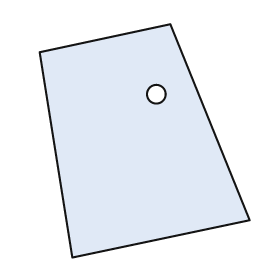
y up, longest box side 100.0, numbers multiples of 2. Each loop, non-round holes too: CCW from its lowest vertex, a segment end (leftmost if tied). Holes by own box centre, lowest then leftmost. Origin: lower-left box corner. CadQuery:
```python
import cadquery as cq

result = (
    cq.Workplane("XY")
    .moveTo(14.0, 0.0)
    .lineTo(90.0, 16.0)
    .lineTo(56.0, 100.0)
    .lineTo(0.0, 88.0)
    .close()
    .moveTo(50.0, 70.0)
    .circle(4.0)
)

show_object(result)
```